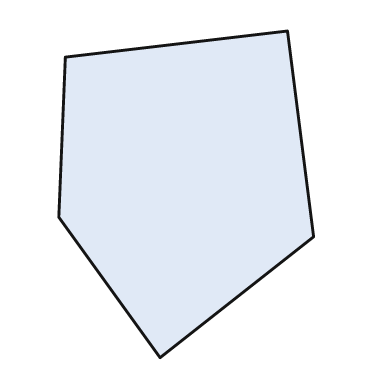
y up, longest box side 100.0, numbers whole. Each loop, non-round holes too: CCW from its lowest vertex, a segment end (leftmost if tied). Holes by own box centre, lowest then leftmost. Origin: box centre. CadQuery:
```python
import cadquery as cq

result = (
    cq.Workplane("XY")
    .moveTo(-8.0, -50.0)
    .lineTo(39.0, -13.0)
    .lineTo(31.0, 50.0)
    .lineTo(-37.0, 42.0)
    .lineTo(-39.0, -7.0)
    .close()
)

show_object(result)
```